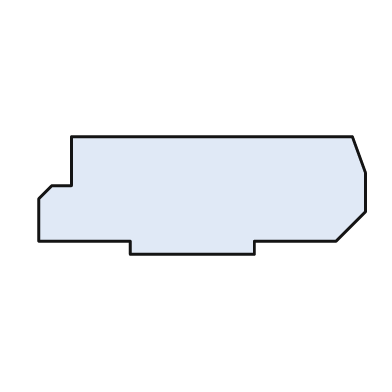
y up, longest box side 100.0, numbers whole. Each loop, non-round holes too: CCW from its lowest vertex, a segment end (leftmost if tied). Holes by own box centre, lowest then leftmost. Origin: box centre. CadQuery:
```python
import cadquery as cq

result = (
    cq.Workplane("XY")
    .moveTo(-22.0, -18.0)
    .lineTo(16.0, -18.0)
    .lineTo(16.0, -14.0)
    .lineTo(41.0, -14.0)
    .lineTo(50.0, -5.0)
    .lineTo(50.0, 7.0)
    .lineTo(46.0, 18.0)
    .lineTo(-40.0, 18.0)
    .lineTo(-40.0, 3.0)
    .lineTo(-46.0, 3.0)
    .lineTo(-50.0, -1.0)
    .lineTo(-50.0, -14.0)
    .lineTo(-22.0, -14.0)
    .close()
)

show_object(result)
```